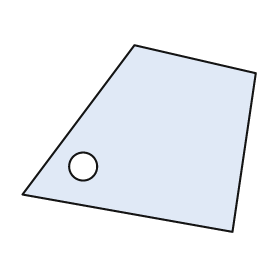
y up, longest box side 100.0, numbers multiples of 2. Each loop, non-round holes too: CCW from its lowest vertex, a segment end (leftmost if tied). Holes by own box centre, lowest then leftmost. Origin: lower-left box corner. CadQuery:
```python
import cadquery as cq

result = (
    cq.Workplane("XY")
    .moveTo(90.0, 0.0)
    .lineTo(100.0, 68.0)
    .lineTo(48.0, 80.0)
    .lineTo(0.0, 16.0)
    .close()
    .moveTo(26.0, 28.0)
    .circle(6.0)
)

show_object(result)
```